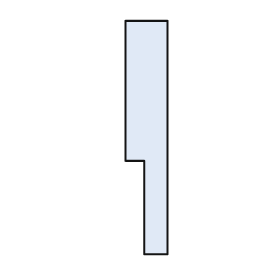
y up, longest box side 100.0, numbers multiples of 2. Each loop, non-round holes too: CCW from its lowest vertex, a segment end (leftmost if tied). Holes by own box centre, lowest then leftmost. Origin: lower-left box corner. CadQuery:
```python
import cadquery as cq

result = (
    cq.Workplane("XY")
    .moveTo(8.0, 0.0)
    .lineTo(18.0, 0.0)
    .lineTo(18.0, 100.0)
    .lineTo(0.0, 100.0)
    .lineTo(0.0, 40.0)
    .lineTo(8.0, 40.0)
    .close()
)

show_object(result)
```